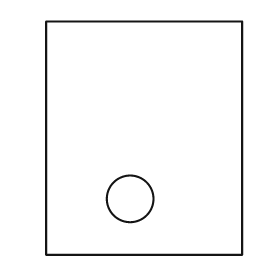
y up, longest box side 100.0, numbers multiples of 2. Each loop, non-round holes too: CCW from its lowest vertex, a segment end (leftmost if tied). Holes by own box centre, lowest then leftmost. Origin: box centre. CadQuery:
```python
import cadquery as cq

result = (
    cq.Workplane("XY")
    .moveTo(-42.0, -50.0)
    .lineTo(42.0, -50.0)
    .lineTo(42.0, 50.0)
    .lineTo(-42.0, 50.0)
    .close()
    .moveTo(-6.0, -26.0)
    .circle(10.0)
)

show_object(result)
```